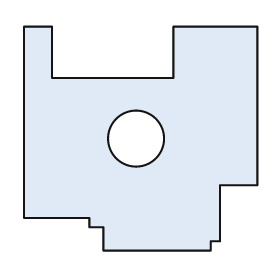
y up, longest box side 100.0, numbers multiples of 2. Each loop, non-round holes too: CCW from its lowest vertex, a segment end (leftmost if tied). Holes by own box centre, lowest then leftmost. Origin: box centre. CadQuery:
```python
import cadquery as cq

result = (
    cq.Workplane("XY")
    .moveTo(-16.0, -48.0)
    .lineTo(30.0, -48.0)
    .lineTo(30.0, -44.0)
    .lineTo(34.0, -44.0)
    .lineTo(34.0, -20.0)
    .lineTo(50.0, -20.0)
    .lineTo(50.0, 48.0)
    .lineTo(14.0, 48.0)
    .lineTo(14.0, 26.0)
    .lineTo(-38.0, 26.0)
    .lineTo(-38.0, 48.0)
    .lineTo(-50.0, 48.0)
    .lineTo(-50.0, -34.0)
    .lineTo(-22.0, -34.0)
    .lineTo(-22.0, -38.0)
    .lineTo(-16.0, -38.0)
    .close()
    .moveTo(-2.0, 0.0)
    .circle(12.0)
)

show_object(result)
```